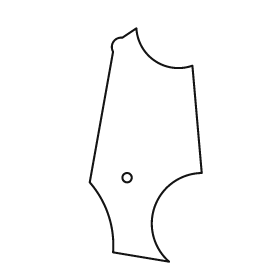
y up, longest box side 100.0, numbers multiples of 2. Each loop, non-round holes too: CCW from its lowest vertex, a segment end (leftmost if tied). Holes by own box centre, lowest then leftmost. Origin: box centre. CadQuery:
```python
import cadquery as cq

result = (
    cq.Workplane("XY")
    .moveTo(10.0, -50.0)
    .threePointArc((4.0, -26.0), (24.0, -12.0))
    .lineTo(20.0, 34.0)
    .threePointArc((4.0, 36.0), (-4.0, 50.0))
    .lineTo(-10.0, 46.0)
    .threePointArc((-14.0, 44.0), (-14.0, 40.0))
    .lineTo(-24.0, -16.0)
    .threePointArc((-16.0, -30.0), (-14.0, -46.0))
    .close()
    .moveTo(-8.0, -14.0)
    .circle(2.0)
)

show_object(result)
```